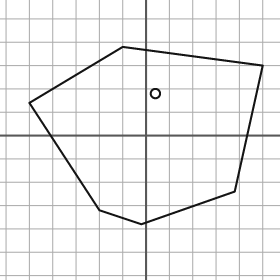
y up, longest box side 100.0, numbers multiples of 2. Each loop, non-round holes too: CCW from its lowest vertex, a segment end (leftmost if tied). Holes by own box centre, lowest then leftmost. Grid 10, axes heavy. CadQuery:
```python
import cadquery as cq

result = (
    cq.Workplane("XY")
    .moveTo(-2.0, -38.0)
    .lineTo(38.0, -24.0)
    .lineTo(50.0, 30.0)
    .lineTo(-10.0, 38.0)
    .lineTo(-50.0, 14.0)
    .lineTo(-20.0, -32.0)
    .close()
    .moveTo(4.0, 18.0)
    .circle(2.0)
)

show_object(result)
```